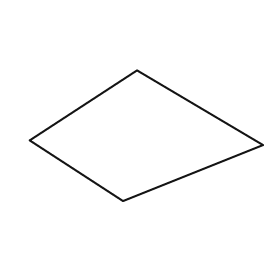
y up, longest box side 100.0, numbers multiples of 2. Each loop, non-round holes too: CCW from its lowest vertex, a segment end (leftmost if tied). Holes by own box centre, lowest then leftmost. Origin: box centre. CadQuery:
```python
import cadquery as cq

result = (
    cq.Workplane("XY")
    .moveTo(-10.0, -28.0)
    .lineTo(50.0, -4.0)
    .lineTo(-4.0, 28.0)
    .lineTo(-50.0, -2.0)
    .close()
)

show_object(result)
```